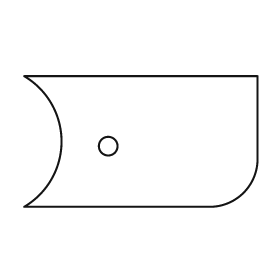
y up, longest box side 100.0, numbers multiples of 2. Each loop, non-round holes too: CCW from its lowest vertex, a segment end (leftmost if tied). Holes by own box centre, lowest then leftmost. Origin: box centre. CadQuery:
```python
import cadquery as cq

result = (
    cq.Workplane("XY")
    .moveTo(-50.0, -28.0)
    .lineTo(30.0, -28.0)
    .threePointArc((44.0, -22.0), (50.0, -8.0))
    .lineTo(50.0, 28.0)
    .lineTo(-50.0, 28.0)
    .threePointArc((-34.0, 0.0), (-50.0, -28.0))
    .close()
    .moveTo(-14.0, -2.0)
    .circle(4.0)
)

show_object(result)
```